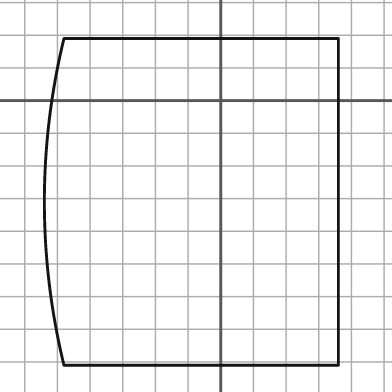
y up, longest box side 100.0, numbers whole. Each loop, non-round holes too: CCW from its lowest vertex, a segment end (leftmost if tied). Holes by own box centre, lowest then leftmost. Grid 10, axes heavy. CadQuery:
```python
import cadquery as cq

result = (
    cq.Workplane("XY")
    .moveTo(-48.0, -81.0)
    .lineTo(36.0, -81.0)
    .lineTo(36.0, 19.0)
    .lineTo(-48.0, 19.0)
    .threePointArc((-54.0, -31.0), (-48.0, -81.0))
    .close()
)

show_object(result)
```